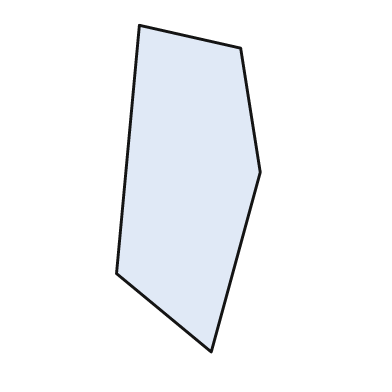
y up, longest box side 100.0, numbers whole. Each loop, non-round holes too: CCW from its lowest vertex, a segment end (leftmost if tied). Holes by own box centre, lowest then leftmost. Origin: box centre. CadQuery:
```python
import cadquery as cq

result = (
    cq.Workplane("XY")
    .moveTo(7.0, -50.0)
    .lineTo(22.0, 5.0)
    .lineTo(16.0, 43.0)
    .lineTo(-15.0, 50.0)
    .lineTo(-22.0, -26.0)
    .close()
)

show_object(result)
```